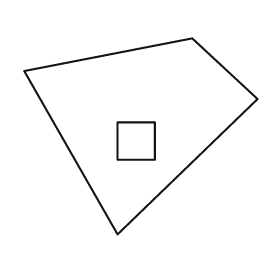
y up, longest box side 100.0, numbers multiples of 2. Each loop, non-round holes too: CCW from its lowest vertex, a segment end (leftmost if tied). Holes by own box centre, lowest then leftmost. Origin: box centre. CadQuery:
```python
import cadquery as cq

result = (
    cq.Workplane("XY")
    .moveTo(-10.0, -42.0)
    .lineTo(50.0, 16.0)
    .lineTo(22.0, 42.0)
    .lineTo(-50.0, 28.0)
    .close()
    .moveTo(-10.0, -10.0)
    .lineTo(6.0, -10.0)
    .lineTo(6.0, 6.0)
    .lineTo(-10.0, 6.0)
    .close()
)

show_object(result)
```